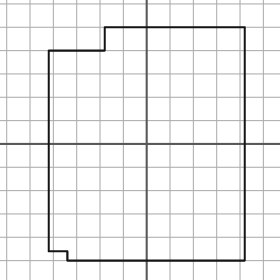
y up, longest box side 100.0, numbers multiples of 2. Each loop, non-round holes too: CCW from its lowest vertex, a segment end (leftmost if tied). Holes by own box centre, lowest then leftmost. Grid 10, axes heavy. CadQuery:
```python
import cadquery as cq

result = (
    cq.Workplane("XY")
    .moveTo(-34.0, -50.0)
    .lineTo(42.0, -50.0)
    .lineTo(42.0, 50.0)
    .lineTo(-18.0, 50.0)
    .lineTo(-18.0, 40.0)
    .lineTo(-42.0, 40.0)
    .lineTo(-42.0, -46.0)
    .lineTo(-34.0, -46.0)
    .close()
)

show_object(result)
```